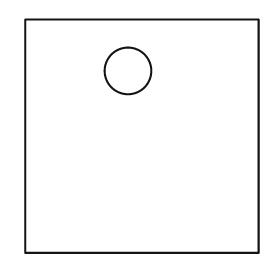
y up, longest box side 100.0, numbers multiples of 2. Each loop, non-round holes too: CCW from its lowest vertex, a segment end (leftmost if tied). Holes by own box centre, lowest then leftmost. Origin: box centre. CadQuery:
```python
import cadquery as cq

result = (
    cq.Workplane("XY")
    .moveTo(-50.0, -50.0)
    .lineTo(50.0, -50.0)
    .lineTo(50.0, 50.0)
    .lineTo(-50.0, 50.0)
    .close()
    .moveTo(-6.0, 28.0)
    .circle(10.0)
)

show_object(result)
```